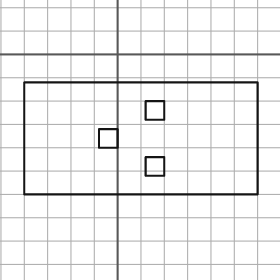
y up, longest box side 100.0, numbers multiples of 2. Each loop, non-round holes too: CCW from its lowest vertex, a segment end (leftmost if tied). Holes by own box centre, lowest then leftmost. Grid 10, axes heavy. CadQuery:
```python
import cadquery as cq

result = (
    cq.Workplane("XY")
    .moveTo(-40.0, -60.0)
    .lineTo(60.0, -60.0)
    .lineTo(60.0, -12.0)
    .lineTo(-40.0, -12.0)
    .close()
    .moveTo(12.0, -52.0)
    .lineTo(20.0, -52.0)
    .lineTo(20.0, -44.0)
    .lineTo(12.0, -44.0)
    .close()
    .moveTo(-8.0, -40.0)
    .lineTo(0.0, -40.0)
    .lineTo(0.0, -32.0)
    .lineTo(-8.0, -32.0)
    .close()
    .moveTo(12.0, -28.0)
    .lineTo(20.0, -28.0)
    .lineTo(20.0, -20.0)
    .lineTo(12.0, -20.0)
    .close()
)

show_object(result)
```